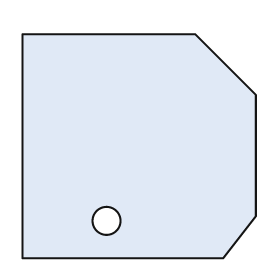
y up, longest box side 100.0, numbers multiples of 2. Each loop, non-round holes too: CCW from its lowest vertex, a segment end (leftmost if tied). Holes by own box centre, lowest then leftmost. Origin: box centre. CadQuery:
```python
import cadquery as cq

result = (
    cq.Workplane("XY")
    .moveTo(-50.0, -48.0)
    .lineTo(36.0, -48.0)
    .lineTo(50.0, -30.0)
    .lineTo(50.0, 22.0)
    .lineTo(24.0, 48.0)
    .lineTo(-50.0, 48.0)
    .close()
    .moveTo(-14.0, -32.0)
    .circle(6.0)
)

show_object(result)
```